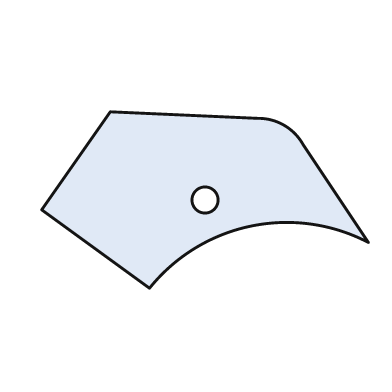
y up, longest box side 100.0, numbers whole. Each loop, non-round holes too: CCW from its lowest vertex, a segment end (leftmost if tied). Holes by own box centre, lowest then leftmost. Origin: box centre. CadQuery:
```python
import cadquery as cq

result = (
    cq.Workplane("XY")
    .moveTo(-17.0, -27.0)
    .threePointArc((14.0, -8.0), (50.0, -13.0))
    .lineTo(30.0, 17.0)
    .threePointArc((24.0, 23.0), (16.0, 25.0))
    .lineTo(-29.0, 27.0)
    .lineTo(-50.0, -3.0)
    .close()
    .moveTo(0.0, 0.0)
    .circle(4.0)
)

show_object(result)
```